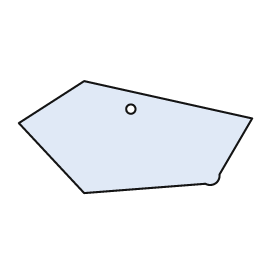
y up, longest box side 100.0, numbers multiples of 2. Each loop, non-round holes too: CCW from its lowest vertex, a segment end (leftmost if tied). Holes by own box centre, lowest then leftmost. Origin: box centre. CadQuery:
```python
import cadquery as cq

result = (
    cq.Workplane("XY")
    .moveTo(-22.0, -24.0)
    .lineTo(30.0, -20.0)
    .threePointArc((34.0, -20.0), (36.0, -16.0))
    .lineTo(50.0, 8.0)
    .lineTo(-22.0, 24.0)
    .lineTo(-50.0, 6.0)
    .close()
    .moveTo(-2.0, 12.0)
    .circle(2.0)
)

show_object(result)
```